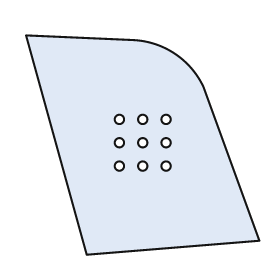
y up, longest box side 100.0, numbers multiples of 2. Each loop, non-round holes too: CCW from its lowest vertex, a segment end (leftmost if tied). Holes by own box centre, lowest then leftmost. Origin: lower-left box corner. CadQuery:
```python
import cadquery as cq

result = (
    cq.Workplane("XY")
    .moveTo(26.0, 0.0)
    .lineTo(100.0, 6.0)
    .lineTo(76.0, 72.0)
    .threePointArc((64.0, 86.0), (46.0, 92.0))
    .lineTo(0.0, 94.0)
    .close()
    .moveTo(40.0, 38.0)
    .circle(2.0)
    .moveTo(50.0, 38.0)
    .circle(2.0)
    .moveTo(60.0, 38.0)
    .circle(2.0)
    .moveTo(40.0, 48.0)
    .circle(2.0)
    .moveTo(50.0, 48.0)
    .circle(2.0)
    .moveTo(60.0, 48.0)
    .circle(2.0)
    .moveTo(40.0, 58.0)
    .circle(2.0)
    .moveTo(50.0, 58.0)
    .circle(2.0)
    .moveTo(60.0, 58.0)
    .circle(2.0)
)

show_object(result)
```